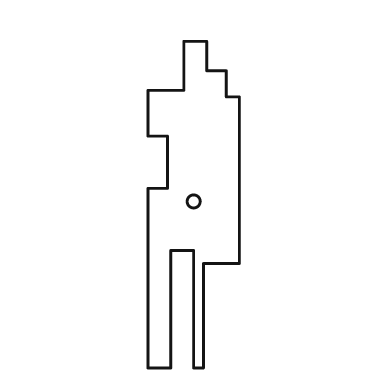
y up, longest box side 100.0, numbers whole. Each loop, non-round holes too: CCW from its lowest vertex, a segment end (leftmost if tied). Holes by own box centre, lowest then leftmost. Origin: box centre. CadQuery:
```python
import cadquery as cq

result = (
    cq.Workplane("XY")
    .moveTo(-14.0, -50.0)
    .lineTo(-7.0, -50.0)
    .lineTo(-7.0, -14.0)
    .lineTo(0.0, -14.0)
    .lineTo(0.0, -50.0)
    .lineTo(3.0, -50.0)
    .lineTo(3.0, -18.0)
    .lineTo(14.0, -18.0)
    .lineTo(14.0, 33.0)
    .lineTo(10.0, 33.0)
    .lineTo(10.0, 41.0)
    .lineTo(4.0, 41.0)
    .lineTo(4.0, 50.0)
    .lineTo(-3.0, 50.0)
    .lineTo(-3.0, 35.0)
    .lineTo(-14.0, 35.0)
    .lineTo(-14.0, 21.0)
    .lineTo(-8.0, 21.0)
    .lineTo(-8.0, 5.0)
    .lineTo(-14.0, 5.0)
    .close()
    .moveTo(0.0, 1.0)
    .circle(2.0)
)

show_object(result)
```